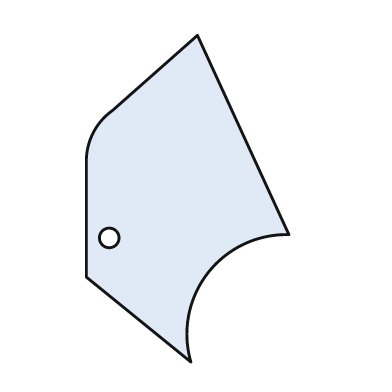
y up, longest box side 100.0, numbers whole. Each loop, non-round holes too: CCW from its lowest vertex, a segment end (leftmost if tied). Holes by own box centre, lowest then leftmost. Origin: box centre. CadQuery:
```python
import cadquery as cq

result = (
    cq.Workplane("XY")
    .moveTo(1.0, -50.0)
    .threePointArc((6.0, -23.0), (31.0, -11.0))
    .lineTo(3.0, 50.0)
    .lineTo(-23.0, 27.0)
    .threePointArc((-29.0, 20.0), (-31.0, 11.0))
    .lineTo(-31.0, -24.0)
    .close()
    .moveTo(-24.0, -12.0)
    .circle(3.0)
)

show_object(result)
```